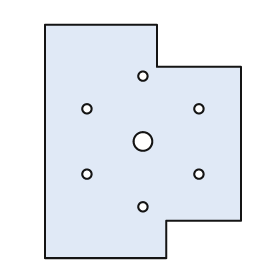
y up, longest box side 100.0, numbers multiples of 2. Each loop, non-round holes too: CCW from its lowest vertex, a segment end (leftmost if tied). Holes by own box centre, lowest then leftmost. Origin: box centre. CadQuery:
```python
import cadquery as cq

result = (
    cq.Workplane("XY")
    .moveTo(-42.0, -50.0)
    .lineTo(10.0, -50.0)
    .lineTo(10.0, -34.0)
    .lineTo(42.0, -34.0)
    .lineTo(42.0, 32.0)
    .lineTo(6.0, 32.0)
    .lineTo(6.0, 50.0)
    .lineTo(-42.0, 50.0)
    .close()
    .moveTo(0.0, -28.0)
    .circle(2.0)
    .moveTo(-24.0, -14.0)
    .circle(2.0)
    .moveTo(24.0, -14.0)
    .circle(2.0)
    .moveTo(0.0, 0.0)
    .circle(4.0)
    .moveTo(-24.0, 14.0)
    .circle(2.0)
    .moveTo(24.0, 14.0)
    .circle(2.0)
    .moveTo(0.0, 28.0)
    .circle(2.0)
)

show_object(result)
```